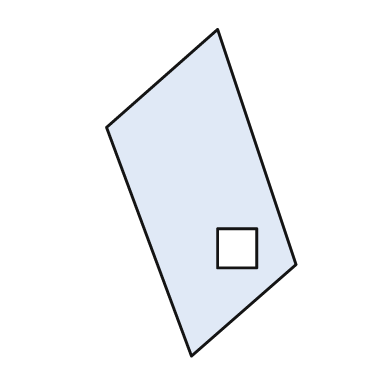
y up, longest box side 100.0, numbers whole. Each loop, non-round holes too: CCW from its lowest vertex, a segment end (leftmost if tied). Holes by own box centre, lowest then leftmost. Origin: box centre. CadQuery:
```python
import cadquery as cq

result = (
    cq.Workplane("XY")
    .moveTo(-3.0, -50.0)
    .lineTo(29.0, -22.0)
    .lineTo(5.0, 50.0)
    .lineTo(-29.0, 20.0)
    .close()
    .moveTo(5.0, -23.0)
    .lineTo(17.0, -23.0)
    .lineTo(17.0, -11.0)
    .lineTo(5.0, -11.0)
    .close()
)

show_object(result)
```